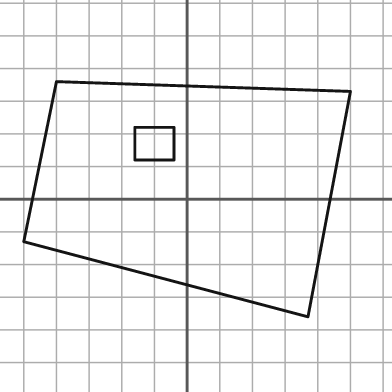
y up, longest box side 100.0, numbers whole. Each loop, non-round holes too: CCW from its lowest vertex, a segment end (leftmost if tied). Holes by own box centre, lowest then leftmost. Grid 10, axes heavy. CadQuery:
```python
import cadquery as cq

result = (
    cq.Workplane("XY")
    .moveTo(37.0, -36.0)
    .lineTo(50.0, 33.0)
    .lineTo(-40.0, 36.0)
    .lineTo(-50.0, -13.0)
    .close()
    .moveTo(-16.0, 12.0)
    .lineTo(-4.0, 12.0)
    .lineTo(-4.0, 22.0)
    .lineTo(-16.0, 22.0)
    .close()
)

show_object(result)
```